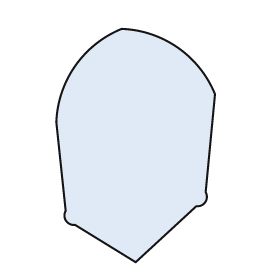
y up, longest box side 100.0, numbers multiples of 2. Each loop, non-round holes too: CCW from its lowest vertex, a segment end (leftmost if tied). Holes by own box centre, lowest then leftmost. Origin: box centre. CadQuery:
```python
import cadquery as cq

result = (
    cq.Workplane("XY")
    .moveTo(0.0, -50.0)
    .lineTo(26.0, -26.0)
    .threePointArc((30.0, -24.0), (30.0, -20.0))
    .lineTo(34.0, 22.0)
    .threePointArc((18.0, 42.0), (-6.0, 50.0))
    .threePointArc((-26.0, 34.0), (-34.0, 10.0))
    .lineTo(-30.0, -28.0)
    .threePointArc((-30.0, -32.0), (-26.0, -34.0))
    .close()
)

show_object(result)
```